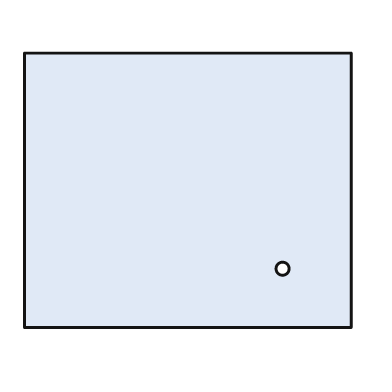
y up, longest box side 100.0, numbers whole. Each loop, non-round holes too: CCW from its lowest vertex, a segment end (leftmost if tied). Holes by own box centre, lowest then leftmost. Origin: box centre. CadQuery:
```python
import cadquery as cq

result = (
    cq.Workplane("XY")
    .moveTo(-50.0, -42.0)
    .lineTo(50.0, -42.0)
    .lineTo(50.0, 42.0)
    .lineTo(-50.0, 42.0)
    .close()
    .moveTo(29.0, -24.0)
    .circle(2.0)
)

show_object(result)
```